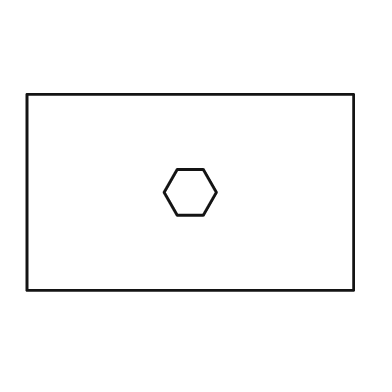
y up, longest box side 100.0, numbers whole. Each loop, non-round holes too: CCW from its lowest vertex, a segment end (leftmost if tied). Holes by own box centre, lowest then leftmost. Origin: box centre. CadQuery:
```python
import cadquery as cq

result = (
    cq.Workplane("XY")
    .moveTo(-50.0, -30.0)
    .lineTo(50.0, -30.0)
    .lineTo(50.0, 30.0)
    .lineTo(-50.0, 30.0)
    .close()
    .moveTo(-4.0, -7.0)
    .lineTo(4.0, -7.0)
    .lineTo(8.0, 0.0)
    .lineTo(4.0, 7.0)
    .lineTo(-4.0, 7.0)
    .lineTo(-8.0, 0.0)
    .close()
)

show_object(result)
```